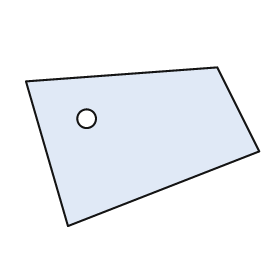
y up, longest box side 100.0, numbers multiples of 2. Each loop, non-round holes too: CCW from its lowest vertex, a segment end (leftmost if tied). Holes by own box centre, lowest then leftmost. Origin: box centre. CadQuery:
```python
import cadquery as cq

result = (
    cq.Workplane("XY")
    .moveTo(-32.0, -34.0)
    .lineTo(50.0, -2.0)
    .lineTo(32.0, 34.0)
    .lineTo(-50.0, 28.0)
    .close()
    .moveTo(-24.0, 12.0)
    .circle(4.0)
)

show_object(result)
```